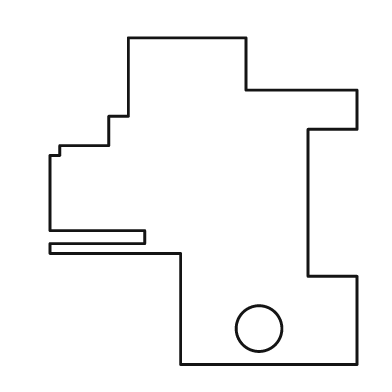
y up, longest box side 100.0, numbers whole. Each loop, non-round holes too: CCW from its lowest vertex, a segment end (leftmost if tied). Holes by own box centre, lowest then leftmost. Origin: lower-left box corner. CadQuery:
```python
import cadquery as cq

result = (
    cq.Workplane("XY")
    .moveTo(40.0, 0.0)
    .lineTo(94.0, 0.0)
    .lineTo(94.0, 27.0)
    .lineTo(79.0, 27.0)
    .lineTo(79.0, 72.0)
    .lineTo(94.0, 72.0)
    .lineTo(94.0, 84.0)
    .lineTo(60.0, 84.0)
    .lineTo(60.0, 100.0)
    .lineTo(24.0, 100.0)
    .lineTo(24.0, 76.0)
    .lineTo(18.0, 76.0)
    .lineTo(18.0, 67.0)
    .lineTo(3.0, 67.0)
    .lineTo(3.0, 64.0)
    .lineTo(0.0, 64.0)
    .lineTo(0.0, 41.0)
    .lineTo(29.0, 41.0)
    .lineTo(29.0, 37.0)
    .lineTo(0.0, 37.0)
    .lineTo(0.0, 34.0)
    .lineTo(40.0, 34.0)
    .close()
    .moveTo(64.0, 11.0)
    .circle(7.0)
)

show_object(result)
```